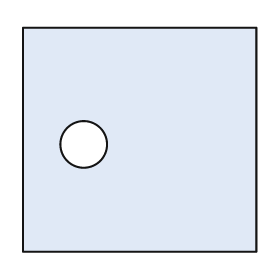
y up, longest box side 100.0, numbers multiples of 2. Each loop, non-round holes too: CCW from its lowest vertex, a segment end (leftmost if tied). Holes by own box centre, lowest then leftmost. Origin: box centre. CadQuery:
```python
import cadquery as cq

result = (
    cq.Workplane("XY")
    .moveTo(-50.0, -48.0)
    .lineTo(50.0, -48.0)
    .lineTo(50.0, 48.0)
    .lineTo(-50.0, 48.0)
    .close()
    .moveTo(-24.0, -2.0)
    .circle(10.0)
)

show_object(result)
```